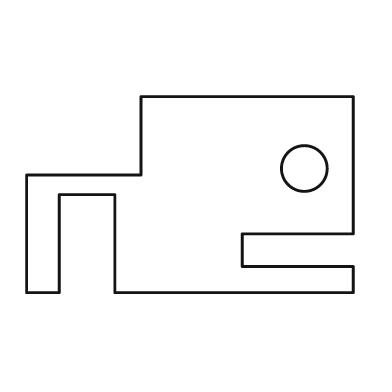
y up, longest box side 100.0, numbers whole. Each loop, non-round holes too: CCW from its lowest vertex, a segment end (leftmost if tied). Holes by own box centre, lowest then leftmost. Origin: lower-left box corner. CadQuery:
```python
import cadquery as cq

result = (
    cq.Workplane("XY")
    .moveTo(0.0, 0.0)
    .lineTo(10.0, 0.0)
    .lineTo(10.0, 30.0)
    .lineTo(27.0, 30.0)
    .lineTo(27.0, 0.0)
    .lineTo(100.0, 0.0)
    .lineTo(100.0, 8.0)
    .lineTo(66.0, 8.0)
    .lineTo(66.0, 18.0)
    .lineTo(100.0, 18.0)
    .lineTo(100.0, 60.0)
    .lineTo(35.0, 60.0)
    .lineTo(35.0, 36.0)
    .lineTo(0.0, 36.0)
    .close()
    .moveTo(85.0, 38.0)
    .circle(7.0)
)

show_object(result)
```